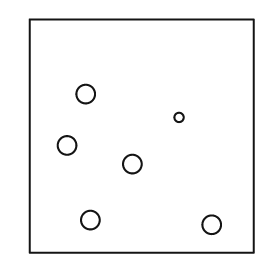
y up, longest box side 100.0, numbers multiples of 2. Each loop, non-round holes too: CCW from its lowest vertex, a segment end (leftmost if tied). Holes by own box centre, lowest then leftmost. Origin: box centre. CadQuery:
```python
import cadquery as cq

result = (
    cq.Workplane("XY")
    .moveTo(-48.0, -50.0)
    .lineTo(48.0, -50.0)
    .lineTo(48.0, 50.0)
    .lineTo(-48.0, 50.0)
    .close()
    .moveTo(30.0, -38.0)
    .circle(4.0)
    .moveTo(-22.0, -36.0)
    .circle(4.0)
    .moveTo(-4.0, -12.0)
    .circle(4.0)
    .moveTo(-32.0, -4.0)
    .circle(4.0)
    .moveTo(16.0, 8.0)
    .circle(2.0)
    .moveTo(-24.0, 18.0)
    .circle(4.0)
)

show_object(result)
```